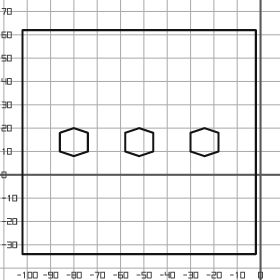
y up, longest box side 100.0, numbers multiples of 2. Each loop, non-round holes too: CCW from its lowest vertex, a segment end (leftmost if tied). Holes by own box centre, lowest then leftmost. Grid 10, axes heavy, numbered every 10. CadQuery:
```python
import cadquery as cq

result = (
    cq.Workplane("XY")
    .moveTo(-102.0, -34.0)
    .lineTo(-2.0, -34.0)
    .lineTo(-2.0, 62.0)
    .lineTo(-102.0, 62.0)
    .close()
    .moveTo(-80.0, 8.0)
    .lineTo(-74.0, 10.0)
    .lineTo(-74.0, 18.0)
    .lineTo(-80.0, 20.0)
    .lineTo(-86.0, 18.0)
    .lineTo(-86.0, 10.0)
    .close()
    .moveTo(-52.0, 8.0)
    .lineTo(-46.0, 10.0)
    .lineTo(-46.0, 18.0)
    .lineTo(-52.0, 20.0)
    .lineTo(-58.0, 18.0)
    .lineTo(-58.0, 10.0)
    .close()
    .moveTo(-24.0, 8.0)
    .lineTo(-18.0, 10.0)
    .lineTo(-18.0, 18.0)
    .lineTo(-24.0, 20.0)
    .lineTo(-30.0, 18.0)
    .lineTo(-30.0, 10.0)
    .close()
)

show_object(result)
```